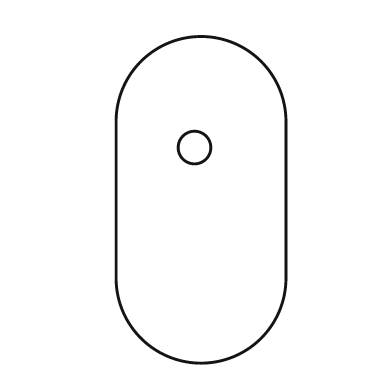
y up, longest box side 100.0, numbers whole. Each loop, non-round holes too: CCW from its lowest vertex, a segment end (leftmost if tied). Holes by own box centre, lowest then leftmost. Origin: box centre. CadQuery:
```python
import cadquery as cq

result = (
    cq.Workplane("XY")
    .moveTo(-26.0, -24.0)
    .threePointArc((0.0, -50.0), (26.0, -24.0))
    .lineTo(26.0, 24.0)
    .threePointArc((0.0, 50.0), (-26.0, 24.0))
    .close()
    .moveTo(-2.0, 16.0)
    .circle(5.0)
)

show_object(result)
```